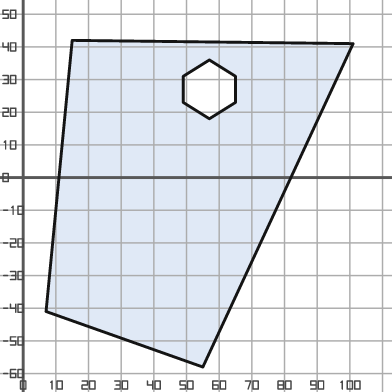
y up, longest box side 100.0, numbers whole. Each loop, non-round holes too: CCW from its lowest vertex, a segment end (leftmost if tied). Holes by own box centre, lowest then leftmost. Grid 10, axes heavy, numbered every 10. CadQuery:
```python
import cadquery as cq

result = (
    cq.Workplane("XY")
    .moveTo(55.0, -58.0)
    .lineTo(101.0, 41.0)
    .lineTo(15.0, 42.0)
    .lineTo(7.0, -41.0)
    .close()
    .moveTo(57.0, 18.0)
    .lineTo(65.0, 23.0)
    .lineTo(65.0, 31.0)
    .lineTo(57.0, 36.0)
    .lineTo(49.0, 31.0)
    .lineTo(49.0, 23.0)
    .close()
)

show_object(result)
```